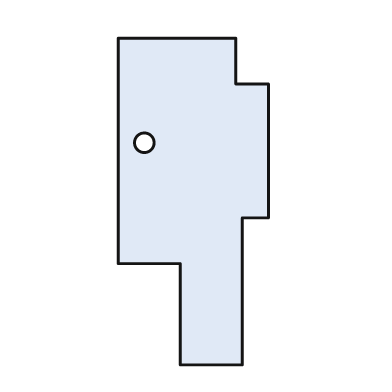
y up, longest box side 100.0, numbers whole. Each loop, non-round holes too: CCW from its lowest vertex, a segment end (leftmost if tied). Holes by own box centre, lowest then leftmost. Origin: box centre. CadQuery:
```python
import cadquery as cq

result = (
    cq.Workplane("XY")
    .moveTo(-4.0, -50.0)
    .lineTo(15.0, -50.0)
    .lineTo(15.0, -5.0)
    .lineTo(23.0, -5.0)
    .lineTo(23.0, 36.0)
    .lineTo(13.0, 36.0)
    .lineTo(13.0, 50.0)
    .lineTo(-23.0, 50.0)
    .lineTo(-23.0, -19.0)
    .lineTo(-4.0, -19.0)
    .close()
    .moveTo(-15.0, 18.0)
    .circle(3.0)
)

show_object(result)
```